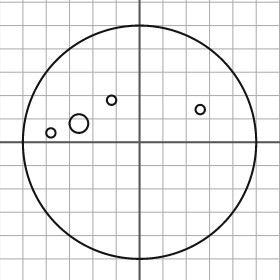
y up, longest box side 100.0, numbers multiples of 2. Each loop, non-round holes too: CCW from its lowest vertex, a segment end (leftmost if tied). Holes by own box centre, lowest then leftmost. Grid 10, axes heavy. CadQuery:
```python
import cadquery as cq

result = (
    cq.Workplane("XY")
    .moveTo(0.0, 0.0)
    .circle(50.0)
    .moveTo(-38.0, 4.0)
    .circle(2.0)
    .moveTo(-26.0, 8.0)
    .circle(4.0)
    .moveTo(26.0, 14.0)
    .circle(2.0)
    .moveTo(-12.0, 18.0)
    .circle(2.0)
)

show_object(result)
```